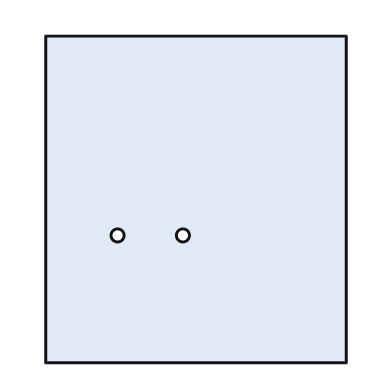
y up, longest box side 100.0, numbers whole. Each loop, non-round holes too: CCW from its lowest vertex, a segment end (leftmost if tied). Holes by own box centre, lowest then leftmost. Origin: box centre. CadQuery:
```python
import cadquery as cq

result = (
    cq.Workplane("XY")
    .moveTo(-46.0, -50.0)
    .lineTo(46.0, -50.0)
    .lineTo(46.0, 50.0)
    .lineTo(-46.0, 50.0)
    .close()
    .moveTo(-24.0, -11.0)
    .circle(2.0)
    .moveTo(-4.0, -11.0)
    .circle(2.0)
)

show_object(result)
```